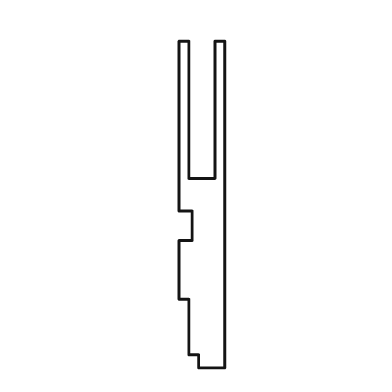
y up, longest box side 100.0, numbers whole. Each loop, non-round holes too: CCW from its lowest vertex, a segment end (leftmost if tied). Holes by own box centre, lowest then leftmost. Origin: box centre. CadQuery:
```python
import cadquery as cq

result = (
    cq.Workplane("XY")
    .moveTo(-1.0, -50.0)
    .lineTo(7.0, -50.0)
    .lineTo(7.0, 50.0)
    .lineTo(4.0, 50.0)
    .lineTo(4.0, 8.0)
    .lineTo(-4.0, 8.0)
    .lineTo(-4.0, 50.0)
    .lineTo(-7.0, 50.0)
    .lineTo(-7.0, -2.0)
    .lineTo(-3.0, -2.0)
    .lineTo(-3.0, -11.0)
    .lineTo(-7.0, -11.0)
    .lineTo(-7.0, -29.0)
    .lineTo(-4.0, -29.0)
    .lineTo(-4.0, -46.0)
    .lineTo(-1.0, -46.0)
    .close()
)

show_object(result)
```